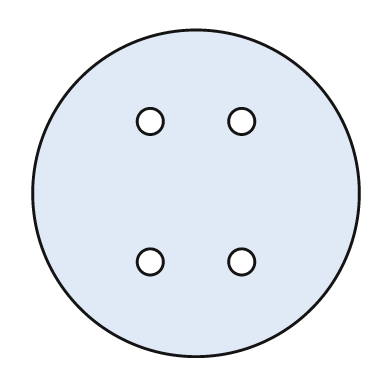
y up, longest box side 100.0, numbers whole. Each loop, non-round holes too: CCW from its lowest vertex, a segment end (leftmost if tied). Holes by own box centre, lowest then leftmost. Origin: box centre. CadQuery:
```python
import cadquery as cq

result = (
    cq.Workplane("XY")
    .moveTo(0.0, 0.0)
    .circle(50.0)
    .moveTo(-14.0, -21.0)
    .circle(4.0)
    .moveTo(14.0, -21.0)
    .circle(4.0)
    .moveTo(-14.0, 22.0)
    .circle(4.0)
    .moveTo(14.0, 22.0)
    .circle(4.0)
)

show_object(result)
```